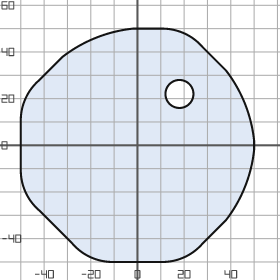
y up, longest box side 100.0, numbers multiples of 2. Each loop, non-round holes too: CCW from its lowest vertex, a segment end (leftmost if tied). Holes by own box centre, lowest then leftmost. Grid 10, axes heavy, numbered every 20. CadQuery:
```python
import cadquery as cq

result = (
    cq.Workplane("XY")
    .moveTo(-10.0, -50.0)
    .lineTo(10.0, -50.0)
    .threePointArc((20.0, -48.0), (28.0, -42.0))
    .lineTo(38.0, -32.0)
    .threePointArc((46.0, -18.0), (50.0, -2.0))
    .lineTo(50.0, 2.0)
    .threePointArc((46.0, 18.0), (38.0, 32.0))
    .lineTo(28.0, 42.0)
    .threePointArc((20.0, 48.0), (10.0, 50.0))
    .lineTo(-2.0, 50.0)
    .threePointArc((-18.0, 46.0), (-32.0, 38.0))
    .lineTo(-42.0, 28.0)
    .threePointArc((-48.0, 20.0), (-50.0, 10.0))
    .lineTo(-50.0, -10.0)
    .threePointArc((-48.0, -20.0), (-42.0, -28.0))
    .lineTo(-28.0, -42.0)
    .threePointArc((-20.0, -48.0), (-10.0, -50.0))
    .close()
    .moveTo(18.0, 22.0)
    .circle(6.0)
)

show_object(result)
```